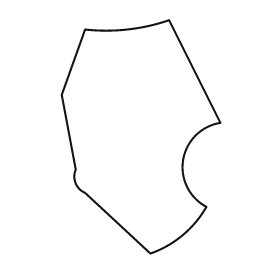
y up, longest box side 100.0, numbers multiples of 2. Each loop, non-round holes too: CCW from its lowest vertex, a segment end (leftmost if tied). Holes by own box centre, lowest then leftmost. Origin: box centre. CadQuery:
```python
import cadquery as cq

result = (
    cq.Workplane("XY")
    .moveTo(4.0, -50.0)
    .threePointArc((18.0, -42.0), (28.0, -30.0))
    .threePointArc((18.0, -10.0), (34.0, 6.0))
    .lineTo(12.0, 50.0)
    .threePointArc((-6.0, 46.0), (-24.0, 46.0))
    .lineTo(-34.0, 18.0)
    .lineTo(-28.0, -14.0)
    .threePointArc((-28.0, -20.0), (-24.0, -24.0))
    .close()
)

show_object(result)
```